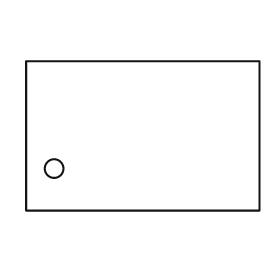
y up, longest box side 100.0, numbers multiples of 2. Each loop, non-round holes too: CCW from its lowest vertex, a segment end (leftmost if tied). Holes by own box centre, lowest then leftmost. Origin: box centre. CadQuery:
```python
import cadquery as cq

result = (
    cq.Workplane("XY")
    .moveTo(-50.0, -32.0)
    .lineTo(50.0, -32.0)
    .lineTo(50.0, 32.0)
    .lineTo(-50.0, 32.0)
    .close()
    .moveTo(-38.0, -14.0)
    .circle(4.0)
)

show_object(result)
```